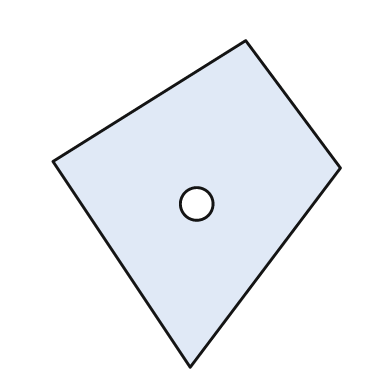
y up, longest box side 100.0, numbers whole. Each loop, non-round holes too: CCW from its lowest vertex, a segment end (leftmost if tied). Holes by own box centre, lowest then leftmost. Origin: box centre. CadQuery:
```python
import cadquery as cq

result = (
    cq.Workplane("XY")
    .moveTo(-2.0, -50.0)
    .lineTo(44.0, 11.0)
    .lineTo(15.0, 50.0)
    .lineTo(-44.0, 13.0)
    .close()
    .moveTo(0.0, 0.0)
    .circle(5.0)
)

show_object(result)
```